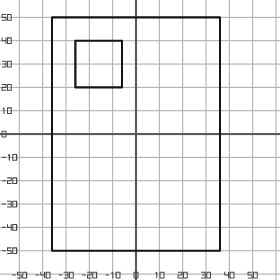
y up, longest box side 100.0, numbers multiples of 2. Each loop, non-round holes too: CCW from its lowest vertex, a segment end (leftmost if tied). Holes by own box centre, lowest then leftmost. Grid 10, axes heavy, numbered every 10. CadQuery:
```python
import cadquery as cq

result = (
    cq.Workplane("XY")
    .moveTo(-36.0, -50.0)
    .lineTo(36.0, -50.0)
    .lineTo(36.0, 50.0)
    .lineTo(-36.0, 50.0)
    .close()
    .moveTo(-26.0, 20.0)
    .lineTo(-6.0, 20.0)
    .lineTo(-6.0, 40.0)
    .lineTo(-26.0, 40.0)
    .close()
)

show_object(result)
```